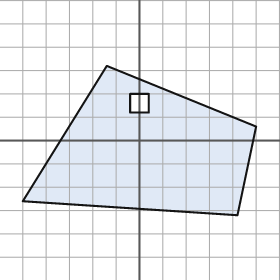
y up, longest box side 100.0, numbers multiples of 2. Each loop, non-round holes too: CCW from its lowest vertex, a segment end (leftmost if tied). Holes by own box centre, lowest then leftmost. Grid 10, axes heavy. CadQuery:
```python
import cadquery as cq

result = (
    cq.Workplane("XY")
    .moveTo(42.0, -32.0)
    .lineTo(50.0, 6.0)
    .lineTo(-14.0, 32.0)
    .lineTo(-50.0, -26.0)
    .close()
    .moveTo(-4.0, 12.0)
    .lineTo(4.0, 12.0)
    .lineTo(4.0, 20.0)
    .lineTo(-4.0, 20.0)
    .close()
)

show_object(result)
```